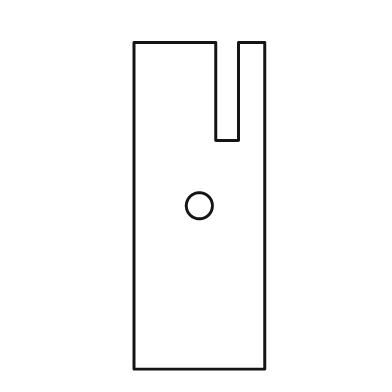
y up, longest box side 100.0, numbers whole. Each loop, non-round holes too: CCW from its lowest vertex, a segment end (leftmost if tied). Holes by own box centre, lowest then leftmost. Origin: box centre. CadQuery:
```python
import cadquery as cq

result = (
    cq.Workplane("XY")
    .moveTo(-20.0, -50.0)
    .lineTo(20.0, -50.0)
    .lineTo(20.0, 50.0)
    .lineTo(12.0, 50.0)
    .lineTo(12.0, 20.0)
    .lineTo(5.0, 20.0)
    .lineTo(5.0, 50.0)
    .lineTo(-20.0, 50.0)
    .close()
    .moveTo(0.0, 0.0)
    .circle(4.0)
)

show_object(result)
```